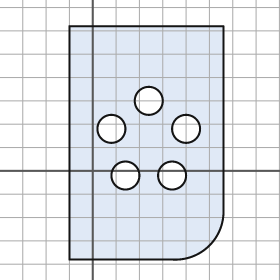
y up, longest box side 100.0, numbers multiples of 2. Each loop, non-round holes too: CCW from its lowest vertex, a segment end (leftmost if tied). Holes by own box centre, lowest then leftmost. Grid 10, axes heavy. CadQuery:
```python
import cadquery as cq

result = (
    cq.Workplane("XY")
    .moveTo(-10.0, -38.0)
    .lineTo(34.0, -38.0)
    .threePointArc((50.0, -32.0), (56.0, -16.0))
    .lineTo(56.0, 62.0)
    .lineTo(-10.0, 62.0)
    .close()
    .moveTo(14.0, -2.0)
    .circle(6.0)
    .moveTo(34.0, -2.0)
    .circle(6.0)
    .moveTo(8.0, 18.0)
    .circle(6.0)
    .moveTo(40.0, 18.0)
    .circle(6.0)
    .moveTo(24.0, 30.0)
    .circle(6.0)
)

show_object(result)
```